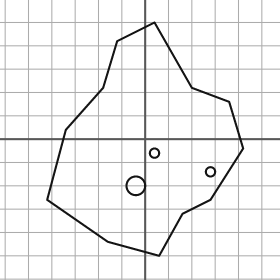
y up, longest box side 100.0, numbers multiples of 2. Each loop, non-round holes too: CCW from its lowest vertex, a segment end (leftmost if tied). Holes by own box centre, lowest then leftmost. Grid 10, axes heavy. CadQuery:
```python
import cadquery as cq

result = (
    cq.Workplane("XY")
    .moveTo(6.0, -50.0)
    .lineTo(16.0, -32.0)
    .lineTo(28.0, -26.0)
    .lineTo(42.0, -4.0)
    .lineTo(36.0, 16.0)
    .lineTo(20.0, 22.0)
    .lineTo(4.0, 50.0)
    .lineTo(-12.0, 42.0)
    .lineTo(-18.0, 22.0)
    .lineTo(-34.0, 4.0)
    .lineTo(-42.0, -26.0)
    .lineTo(-16.0, -44.0)
    .close()
    .moveTo(-4.0, -20.0)
    .circle(4.0)
    .moveTo(28.0, -14.0)
    .circle(2.0)
    .moveTo(4.0, -6.0)
    .circle(2.0)
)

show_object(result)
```